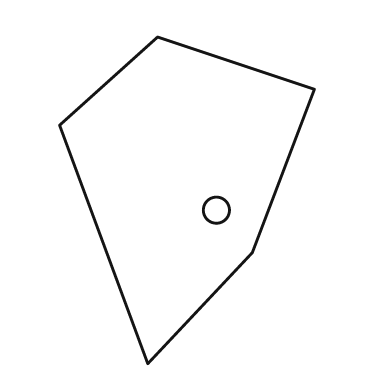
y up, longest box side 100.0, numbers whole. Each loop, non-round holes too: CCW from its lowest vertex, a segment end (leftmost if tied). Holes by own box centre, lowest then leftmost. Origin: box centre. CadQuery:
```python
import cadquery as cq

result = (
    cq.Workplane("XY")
    .moveTo(-12.0, -50.0)
    .lineTo(20.0, -16.0)
    .lineTo(39.0, 34.0)
    .lineTo(-9.0, 50.0)
    .lineTo(-39.0, 23.0)
    .close()
    .moveTo(9.0, -3.0)
    .circle(4.0)
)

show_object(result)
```